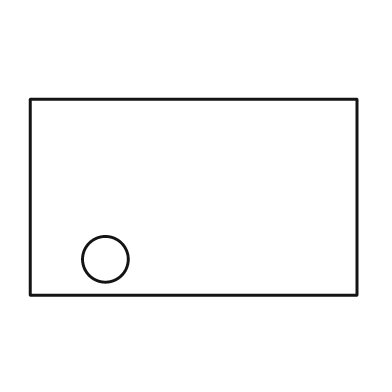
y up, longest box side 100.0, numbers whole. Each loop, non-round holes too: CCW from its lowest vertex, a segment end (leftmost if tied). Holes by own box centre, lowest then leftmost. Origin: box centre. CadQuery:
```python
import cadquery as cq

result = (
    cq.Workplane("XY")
    .moveTo(-50.0, -30.0)
    .lineTo(50.0, -30.0)
    .lineTo(50.0, 30.0)
    .lineTo(-50.0, 30.0)
    .close()
    .moveTo(-27.0, -19.0)
    .circle(7.0)
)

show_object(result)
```